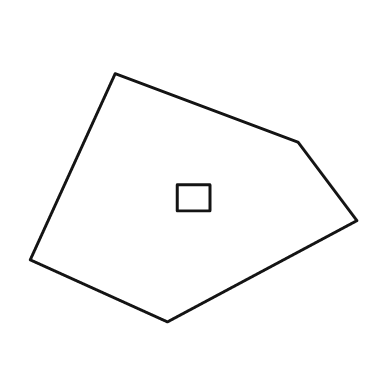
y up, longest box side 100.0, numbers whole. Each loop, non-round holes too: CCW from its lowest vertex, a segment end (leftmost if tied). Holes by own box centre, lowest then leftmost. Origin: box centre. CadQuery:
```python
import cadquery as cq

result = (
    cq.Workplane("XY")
    .moveTo(-8.0, -38.0)
    .lineTo(50.0, -7.0)
    .lineTo(32.0, 17.0)
    .lineTo(-24.0, 38.0)
    .lineTo(-50.0, -19.0)
    .close()
    .moveTo(-5.0, -4.0)
    .lineTo(5.0, -4.0)
    .lineTo(5.0, 4.0)
    .lineTo(-5.0, 4.0)
    .close()
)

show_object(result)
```